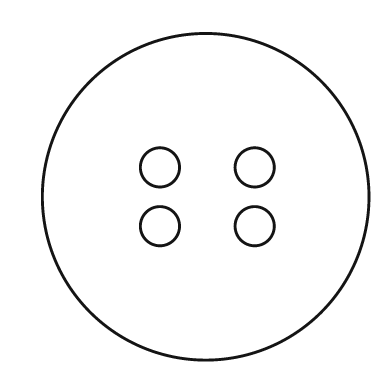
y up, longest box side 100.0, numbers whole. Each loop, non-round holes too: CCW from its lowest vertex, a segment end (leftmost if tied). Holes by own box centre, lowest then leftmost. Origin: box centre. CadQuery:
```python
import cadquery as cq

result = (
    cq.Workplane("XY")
    .moveTo(0.0, 0.0)
    .circle(50.0)
    .moveTo(-14.0, -9.0)
    .circle(6.0)
    .moveTo(15.0, -9.0)
    .circle(6.0)
    .moveTo(-14.0, 9.0)
    .circle(6.0)
    .moveTo(15.0, 9.0)
    .circle(6.0)
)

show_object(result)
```